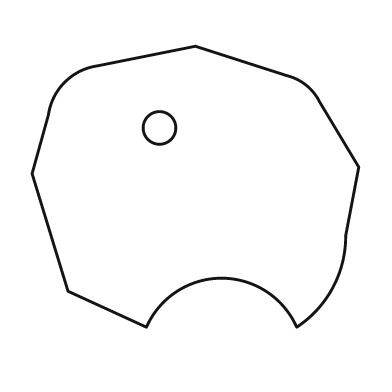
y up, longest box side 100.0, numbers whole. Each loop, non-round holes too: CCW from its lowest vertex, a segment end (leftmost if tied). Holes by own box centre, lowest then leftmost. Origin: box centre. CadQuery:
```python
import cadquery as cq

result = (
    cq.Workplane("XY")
    .moveTo(-15.0, -43.0)
    .threePointArc((8.0, -28.0), (31.0, -43.0))
    .threePointArc((42.0, -31.0), (46.0, -15.0))
    .lineTo(50.0, 6.0)
    .lineTo(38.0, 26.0)
    .threePointArc((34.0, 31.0), (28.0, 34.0))
    .lineTo(0.0, 43.0)
    .lineTo(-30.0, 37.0)
    .threePointArc((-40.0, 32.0), (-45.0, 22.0))
    .lineTo(-50.0, 4.0)
    .lineTo(-39.0, -32.0)
    .close()
    .moveTo(-11.0, 18.0)
    .circle(5.0)
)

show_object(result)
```